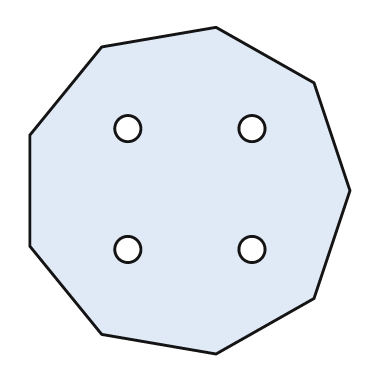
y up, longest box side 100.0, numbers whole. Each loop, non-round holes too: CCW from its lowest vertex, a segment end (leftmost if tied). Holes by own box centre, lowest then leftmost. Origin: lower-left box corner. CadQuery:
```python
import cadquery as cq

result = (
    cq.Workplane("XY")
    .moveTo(57.0, 0.0)
    .lineTo(87.0, 17.0)
    .lineTo(98.0, 50.0)
    .lineTo(87.0, 83.0)
    .lineTo(57.0, 100.0)
    .lineTo(22.0, 94.0)
    .lineTo(0.0, 67.0)
    .lineTo(0.0, 33.0)
    .lineTo(22.0, 6.0)
    .close()
    .moveTo(30.0, 32.0)
    .circle(4.0)
    .moveTo(68.0, 32.0)
    .circle(4.0)
    .moveTo(30.0, 69.0)
    .circle(4.0)
    .moveTo(68.0, 69.0)
    .circle(4.0)
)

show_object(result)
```